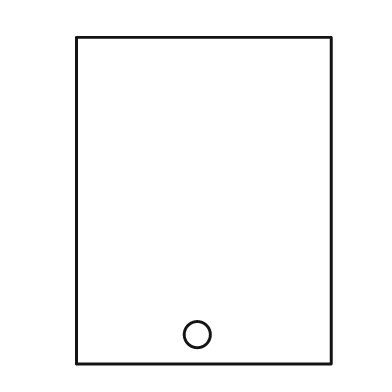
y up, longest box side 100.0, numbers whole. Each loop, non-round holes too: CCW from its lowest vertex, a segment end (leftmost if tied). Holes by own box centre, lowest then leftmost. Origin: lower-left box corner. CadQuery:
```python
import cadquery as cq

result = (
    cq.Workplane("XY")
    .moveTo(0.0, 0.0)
    .lineTo(78.0, 0.0)
    .lineTo(78.0, 100.0)
    .lineTo(0.0, 100.0)
    .close()
    .moveTo(37.0, 9.0)
    .circle(4.0)
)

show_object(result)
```